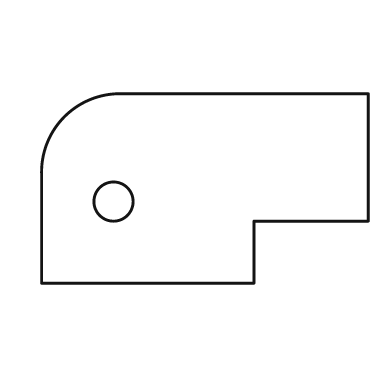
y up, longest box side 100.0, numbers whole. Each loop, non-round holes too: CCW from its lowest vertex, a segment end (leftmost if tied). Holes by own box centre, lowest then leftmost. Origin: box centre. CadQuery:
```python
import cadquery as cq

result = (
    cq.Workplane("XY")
    .moveTo(-50.0, -29.0)
    .lineTo(15.0, -29.0)
    .lineTo(15.0, -10.0)
    .lineTo(50.0, -10.0)
    .lineTo(50.0, 29.0)
    .lineTo(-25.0, 29.0)
    .threePointArc((-43.0, 22.0), (-50.0, 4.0))
    .close()
    .moveTo(-28.0, -4.0)
    .circle(6.0)
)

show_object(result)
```